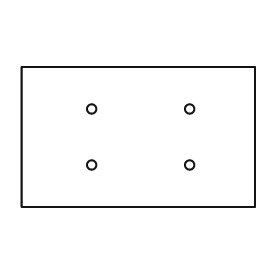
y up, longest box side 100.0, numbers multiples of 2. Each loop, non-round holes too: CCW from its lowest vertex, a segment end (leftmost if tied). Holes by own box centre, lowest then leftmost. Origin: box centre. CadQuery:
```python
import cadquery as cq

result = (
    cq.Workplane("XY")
    .moveTo(-50.0, -30.0)
    .lineTo(50.0, -30.0)
    .lineTo(50.0, 30.0)
    .lineTo(-50.0, 30.0)
    .close()
    .moveTo(-20.0, -12.0)
    .circle(2.0)
    .moveTo(22.0, -12.0)
    .circle(2.0)
    .moveTo(-20.0, 12.0)
    .circle(2.0)
    .moveTo(22.0, 12.0)
    .circle(2.0)
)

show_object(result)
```